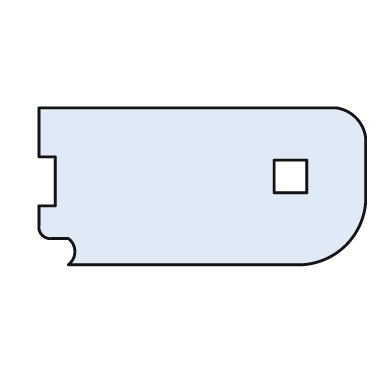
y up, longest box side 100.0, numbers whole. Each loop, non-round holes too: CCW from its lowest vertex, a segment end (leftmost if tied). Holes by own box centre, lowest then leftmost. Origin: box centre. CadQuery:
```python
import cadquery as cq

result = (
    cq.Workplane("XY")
    .moveTo(-41.0, -24.0)
    .lineTo(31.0, -24.0)
    .threePointArc((44.0, -18.0), (50.0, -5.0))
    .lineTo(50.0, 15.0)
    .threePointArc((47.0, 21.0), (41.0, 24.0))
    .lineTo(-50.0, 24.0)
    .lineTo(-50.0, 9.0)
    .lineTo(-45.0, 9.0)
    .lineTo(-45.0, -6.0)
    .lineTo(-50.0, -6.0)
    .lineTo(-50.0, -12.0)
    .threePointArc((-49.0, -15.0), (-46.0, -16.0))
    .lineTo(-41.0, -16.0)
    .threePointArc((-39.0, -20.0), (-41.0, -24.0))
    .close()
    .moveTo(22.0, -2.0)
    .lineTo(32.0, -2.0)
    .lineTo(32.0, 8.0)
    .lineTo(22.0, 8.0)
    .close()
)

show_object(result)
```